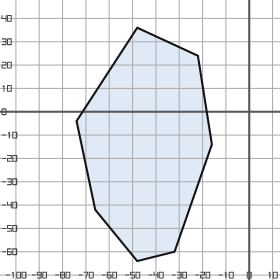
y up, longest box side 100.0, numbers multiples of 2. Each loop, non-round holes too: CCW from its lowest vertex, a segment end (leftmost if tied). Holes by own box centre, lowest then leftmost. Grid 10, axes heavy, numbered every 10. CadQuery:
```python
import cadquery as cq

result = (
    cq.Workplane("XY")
    .moveTo(-48.0, -64.0)
    .lineTo(-32.0, -60.0)
    .lineTo(-16.0, -14.0)
    .lineTo(-22.0, 24.0)
    .lineTo(-48.0, 36.0)
    .lineTo(-74.0, -4.0)
    .lineTo(-66.0, -42.0)
    .close()
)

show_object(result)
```